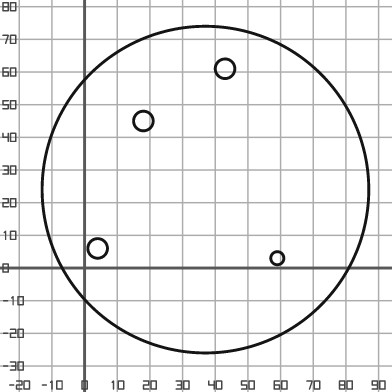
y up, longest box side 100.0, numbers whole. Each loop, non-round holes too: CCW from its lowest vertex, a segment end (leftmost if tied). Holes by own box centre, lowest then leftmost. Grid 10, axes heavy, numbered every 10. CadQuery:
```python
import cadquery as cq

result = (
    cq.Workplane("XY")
    .moveTo(37.0, 24.0)
    .circle(50.0)
    .moveTo(59.0, 3.0)
    .circle(2.0)
    .moveTo(4.0, 6.0)
    .circle(3.0)
    .moveTo(18.0, 45.0)
    .circle(3.0)
    .moveTo(43.0, 61.0)
    .circle(3.0)
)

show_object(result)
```